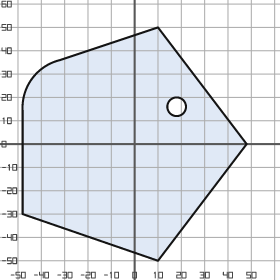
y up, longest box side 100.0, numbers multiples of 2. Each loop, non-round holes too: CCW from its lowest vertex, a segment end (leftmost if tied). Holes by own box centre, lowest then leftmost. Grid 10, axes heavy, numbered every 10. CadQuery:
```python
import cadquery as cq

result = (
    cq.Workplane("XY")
    .moveTo(10.0, -50.0)
    .lineTo(48.0, 0.0)
    .lineTo(10.0, 50.0)
    .lineTo(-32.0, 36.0)
    .threePointArc((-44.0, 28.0), (-48.0, 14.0))
    .lineTo(-48.0, -30.0)
    .close()
    .moveTo(18.0, 16.0)
    .circle(4.0)
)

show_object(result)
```